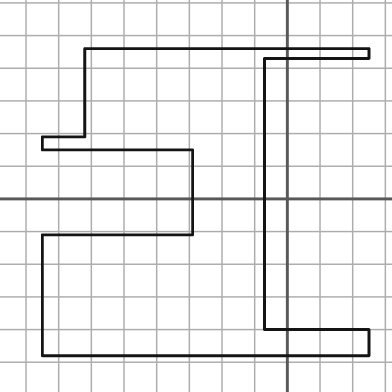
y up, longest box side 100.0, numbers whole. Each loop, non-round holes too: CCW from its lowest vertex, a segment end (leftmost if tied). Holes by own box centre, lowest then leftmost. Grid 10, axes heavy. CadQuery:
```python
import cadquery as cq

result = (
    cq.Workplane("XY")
    .moveTo(-75.0, -48.0)
    .lineTo(25.0, -48.0)
    .lineTo(25.0, -40.0)
    .lineTo(-7.0, -40.0)
    .lineTo(-7.0, 43.0)
    .lineTo(25.0, 43.0)
    .lineTo(25.0, 46.0)
    .lineTo(-62.0, 46.0)
    .lineTo(-62.0, 19.0)
    .lineTo(-75.0, 19.0)
    .lineTo(-75.0, 15.0)
    .lineTo(-29.0, 15.0)
    .lineTo(-29.0, -11.0)
    .lineTo(-75.0, -11.0)
    .close()
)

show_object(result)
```